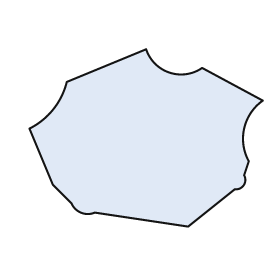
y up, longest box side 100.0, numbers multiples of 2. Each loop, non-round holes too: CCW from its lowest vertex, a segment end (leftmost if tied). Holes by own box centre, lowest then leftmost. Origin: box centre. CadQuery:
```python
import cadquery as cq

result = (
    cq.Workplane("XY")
    .moveTo(18.0, -38.0)
    .lineTo(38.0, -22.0)
    .threePointArc((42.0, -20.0), (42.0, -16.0))
    .lineTo(44.0, -10.0)
    .threePointArc((42.0, 4.0), (50.0, 16.0))
    .lineTo(24.0, 30.0)
    .threePointArc((10.0, 28.0), (0.0, 38.0))
    .lineTo(-34.0, 24.0)
    .threePointArc((-40.0, 12.0), (-50.0, 4.0))
    .lineTo(-40.0, -20.0)
    .lineTo(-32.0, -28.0)
    .threePointArc((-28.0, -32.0), (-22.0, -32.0))
    .close()
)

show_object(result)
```